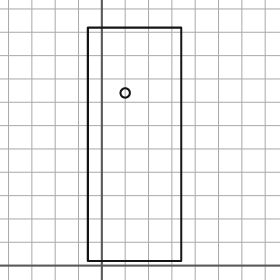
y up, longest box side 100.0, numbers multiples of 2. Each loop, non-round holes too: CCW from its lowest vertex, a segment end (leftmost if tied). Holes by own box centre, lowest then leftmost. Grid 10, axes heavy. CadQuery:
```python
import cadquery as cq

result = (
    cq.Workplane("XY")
    .moveTo(-6.0, 2.0)
    .lineTo(34.0, 2.0)
    .lineTo(34.0, 102.0)
    .lineTo(-6.0, 102.0)
    .close()
    .moveTo(10.0, 74.0)
    .circle(2.0)
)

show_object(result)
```